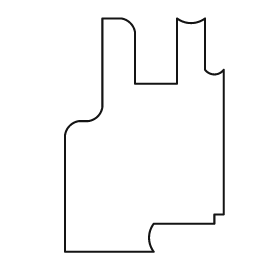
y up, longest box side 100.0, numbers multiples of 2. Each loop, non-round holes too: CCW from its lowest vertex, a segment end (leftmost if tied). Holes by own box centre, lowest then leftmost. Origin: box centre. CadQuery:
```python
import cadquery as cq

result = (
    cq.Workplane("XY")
    .moveTo(-34.0, -50.0)
    .lineTo(4.0, -50.0)
    .threePointArc((2.0, -44.0), (4.0, -38.0))
    .lineTo(30.0, -38.0)
    .lineTo(30.0, -34.0)
    .lineTo(34.0, -34.0)
    .lineTo(34.0, 28.0)
    .threePointArc((30.0, 26.0), (26.0, 28.0))
    .lineTo(26.0, 50.0)
    .threePointArc((20.0, 48.0), (14.0, 50.0))
    .lineTo(14.0, 22.0)
    .lineTo(-4.0, 22.0)
    .lineTo(-4.0, 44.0)
    .threePointArc((-6.0, 48.0), (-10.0, 50.0))
    .lineTo(-18.0, 50.0)
    .lineTo(-18.0, 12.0)
    .threePointArc((-20.0, 8.0), (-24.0, 6.0))
    .lineTo(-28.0, 6.0)
    .threePointArc((-32.0, 4.0), (-34.0, 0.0))
    .close()
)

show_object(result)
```